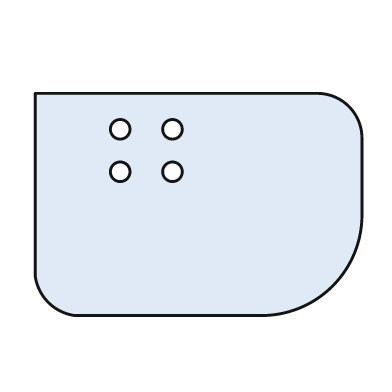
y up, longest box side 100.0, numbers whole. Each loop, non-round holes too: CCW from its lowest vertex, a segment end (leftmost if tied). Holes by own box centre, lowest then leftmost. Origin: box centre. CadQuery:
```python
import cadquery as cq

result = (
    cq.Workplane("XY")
    .moveTo(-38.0, -34.0)
    .lineTo(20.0, -34.0)
    .threePointArc((41.0, -25.0), (50.0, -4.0))
    .lineTo(50.0, 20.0)
    .threePointArc((46.0, 30.0), (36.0, 34.0))
    .lineTo(-50.0, 34.0)
    .lineTo(-50.0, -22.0)
    .threePointArc((-46.0, -30.0), (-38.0, -34.0))
    .close()
    .moveTo(-24.0, 10.0)
    .circle(3.0)
    .moveTo(-8.0, 10.0)
    .circle(3.0)
    .moveTo(-24.0, 23.0)
    .circle(3.0)
    .moveTo(-8.0, 23.0)
    .circle(3.0)
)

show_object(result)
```